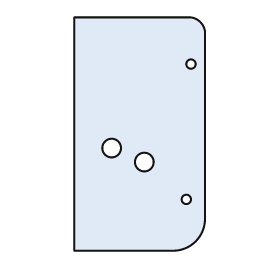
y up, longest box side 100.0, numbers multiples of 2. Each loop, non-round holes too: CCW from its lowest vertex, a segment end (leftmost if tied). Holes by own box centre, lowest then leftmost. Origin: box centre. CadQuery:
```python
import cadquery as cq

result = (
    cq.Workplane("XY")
    .moveTo(-28.0, -50.0)
    .lineTo(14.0, -50.0)
    .threePointArc((24.0, -46.0), (28.0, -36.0))
    .lineTo(28.0, 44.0)
    .threePointArc((26.0, 48.0), (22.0, 50.0))
    .lineTo(-28.0, 50.0)
    .close()
    .moveTo(20.0, -28.0)
    .circle(2.0)
    .moveTo(2.0, -12.0)
    .circle(4.0)
    .moveTo(-12.0, -6.0)
    .circle(4.0)
    .moveTo(22.0, 30.0)
    .circle(2.0)
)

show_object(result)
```